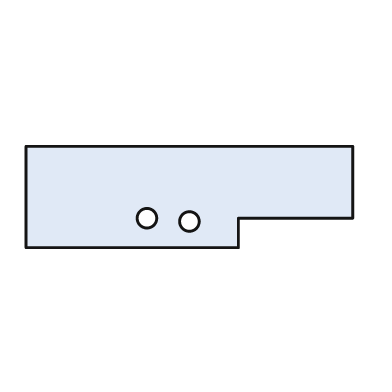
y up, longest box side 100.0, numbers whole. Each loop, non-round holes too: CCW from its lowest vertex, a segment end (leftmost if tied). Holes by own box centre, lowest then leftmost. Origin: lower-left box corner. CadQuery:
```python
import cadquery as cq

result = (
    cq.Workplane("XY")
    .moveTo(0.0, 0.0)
    .lineTo(65.0, 0.0)
    .lineTo(65.0, 9.0)
    .lineTo(100.0, 9.0)
    .lineTo(100.0, 31.0)
    .lineTo(0.0, 31.0)
    .close()
    .moveTo(50.0, 8.0)
    .circle(3.0)
    .moveTo(37.0, 9.0)
    .circle(3.0)
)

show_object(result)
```